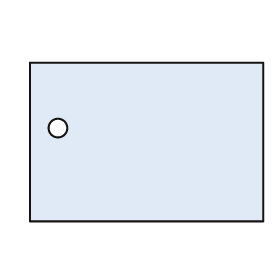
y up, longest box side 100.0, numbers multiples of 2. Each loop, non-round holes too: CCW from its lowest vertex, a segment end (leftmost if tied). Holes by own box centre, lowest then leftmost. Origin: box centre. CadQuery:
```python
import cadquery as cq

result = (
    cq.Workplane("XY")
    .moveTo(-50.0, -34.0)
    .lineTo(50.0, -34.0)
    .lineTo(50.0, 34.0)
    .lineTo(-50.0, 34.0)
    .close()
    .moveTo(-38.0, 6.0)
    .circle(4.0)
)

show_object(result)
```